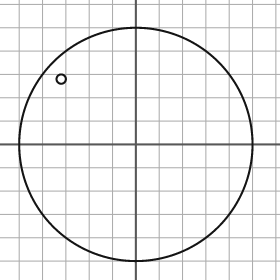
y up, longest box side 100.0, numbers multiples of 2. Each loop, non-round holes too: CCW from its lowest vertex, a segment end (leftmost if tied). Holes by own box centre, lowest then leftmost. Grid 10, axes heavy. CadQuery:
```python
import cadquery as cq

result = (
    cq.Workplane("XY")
    .moveTo(0.0, 0.0)
    .circle(50.0)
    .moveTo(-32.0, 28.0)
    .circle(2.0)
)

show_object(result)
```